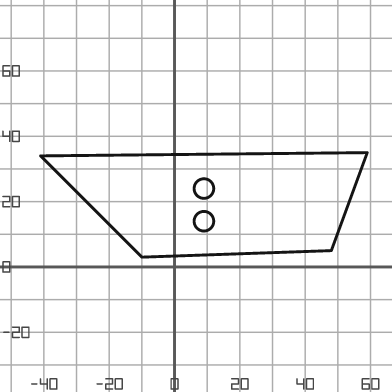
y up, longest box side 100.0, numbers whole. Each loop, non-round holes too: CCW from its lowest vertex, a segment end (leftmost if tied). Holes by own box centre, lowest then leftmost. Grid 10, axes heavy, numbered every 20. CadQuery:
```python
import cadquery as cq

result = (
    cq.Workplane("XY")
    .moveTo(-10.0, 3.0)
    .lineTo(48.0, 5.0)
    .lineTo(59.0, 35.0)
    .lineTo(-41.0, 34.0)
    .close()
    .moveTo(9.0, 14.0)
    .circle(3.0)
    .moveTo(9.0, 24.0)
    .circle(3.0)
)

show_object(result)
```